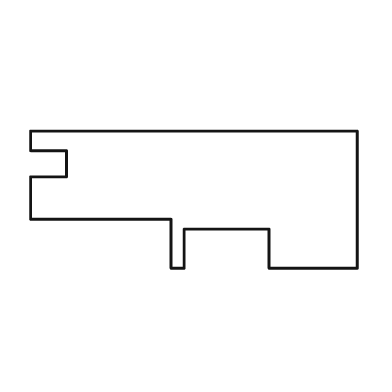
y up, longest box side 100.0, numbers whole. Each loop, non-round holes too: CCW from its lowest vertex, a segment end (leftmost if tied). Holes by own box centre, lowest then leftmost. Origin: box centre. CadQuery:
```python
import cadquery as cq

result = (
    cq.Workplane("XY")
    .moveTo(-7.0, -21.0)
    .lineTo(-3.0, -21.0)
    .lineTo(-3.0, -9.0)
    .lineTo(23.0, -9.0)
    .lineTo(23.0, -21.0)
    .lineTo(50.0, -21.0)
    .lineTo(50.0, 21.0)
    .lineTo(-50.0, 21.0)
    .lineTo(-50.0, 15.0)
    .lineTo(-39.0, 15.0)
    .lineTo(-39.0, 7.0)
    .lineTo(-50.0, 7.0)
    .lineTo(-50.0, -6.0)
    .lineTo(-7.0, -6.0)
    .close()
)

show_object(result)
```